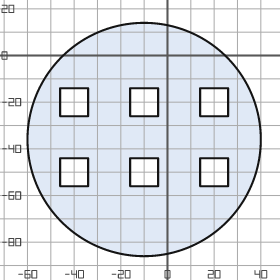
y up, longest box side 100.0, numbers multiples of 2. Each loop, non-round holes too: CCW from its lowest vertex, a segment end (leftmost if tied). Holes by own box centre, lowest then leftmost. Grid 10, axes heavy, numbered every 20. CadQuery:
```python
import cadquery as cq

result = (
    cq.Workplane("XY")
    .moveTo(-10.0, -36.0)
    .circle(50.0)
    .moveTo(-46.0, -56.0)
    .lineTo(-34.0, -56.0)
    .lineTo(-34.0, -44.0)
    .lineTo(-46.0, -44.0)
    .close()
    .moveTo(-16.0, -56.0)
    .lineTo(-4.0, -56.0)
    .lineTo(-4.0, -44.0)
    .lineTo(-16.0, -44.0)
    .close()
    .moveTo(14.0, -56.0)
    .lineTo(26.0, -56.0)
    .lineTo(26.0, -44.0)
    .lineTo(14.0, -44.0)
    .close()
    .moveTo(-46.0, -26.0)
    .lineTo(-34.0, -26.0)
    .lineTo(-34.0, -14.0)
    .lineTo(-46.0, -14.0)
    .close()
    .moveTo(-16.0, -26.0)
    .lineTo(-4.0, -26.0)
    .lineTo(-4.0, -14.0)
    .lineTo(-16.0, -14.0)
    .close()
    .moveTo(14.0, -26.0)
    .lineTo(26.0, -26.0)
    .lineTo(26.0, -14.0)
    .lineTo(14.0, -14.0)
    .close()
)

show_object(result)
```